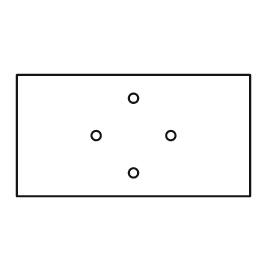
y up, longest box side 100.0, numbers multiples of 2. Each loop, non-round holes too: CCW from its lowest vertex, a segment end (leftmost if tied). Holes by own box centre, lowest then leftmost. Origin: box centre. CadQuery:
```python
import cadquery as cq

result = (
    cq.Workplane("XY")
    .moveTo(-50.0, -26.0)
    .lineTo(50.0, -26.0)
    .lineTo(50.0, 26.0)
    .lineTo(-50.0, 26.0)
    .close()
    .moveTo(0.0, -16.0)
    .circle(2.0)
    .moveTo(-16.0, 0.0)
    .circle(2.0)
    .moveTo(16.0, 0.0)
    .circle(2.0)
    .moveTo(0.0, 16.0)
    .circle(2.0)
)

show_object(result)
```